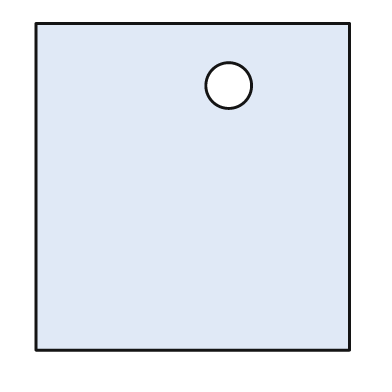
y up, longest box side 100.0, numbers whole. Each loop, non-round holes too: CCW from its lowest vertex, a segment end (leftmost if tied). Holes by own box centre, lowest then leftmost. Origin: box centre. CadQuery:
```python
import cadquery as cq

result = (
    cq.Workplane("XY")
    .moveTo(-48.0, -50.0)
    .lineTo(48.0, -50.0)
    .lineTo(48.0, 50.0)
    .lineTo(-48.0, 50.0)
    .close()
    .moveTo(11.0, 31.0)
    .circle(7.0)
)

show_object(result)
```